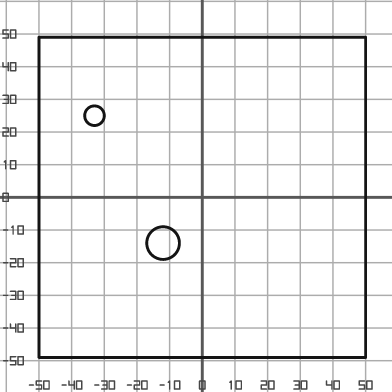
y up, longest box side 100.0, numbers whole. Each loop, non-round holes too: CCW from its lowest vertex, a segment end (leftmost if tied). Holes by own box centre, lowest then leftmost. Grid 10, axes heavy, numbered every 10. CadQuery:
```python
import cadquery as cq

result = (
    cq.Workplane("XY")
    .moveTo(-50.0, -49.0)
    .lineTo(50.0, -49.0)
    .lineTo(50.0, 49.0)
    .lineTo(-50.0, 49.0)
    .close()
    .moveTo(-12.0, -14.0)
    .circle(5.0)
    .moveTo(-33.0, 25.0)
    .circle(3.0)
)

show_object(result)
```